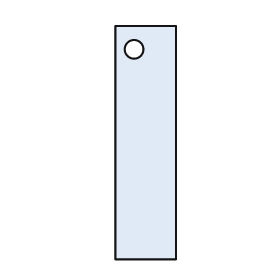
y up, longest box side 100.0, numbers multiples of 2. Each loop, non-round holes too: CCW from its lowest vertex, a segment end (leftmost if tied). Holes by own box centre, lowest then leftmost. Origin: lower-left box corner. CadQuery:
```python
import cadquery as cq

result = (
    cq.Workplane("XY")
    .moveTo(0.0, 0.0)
    .lineTo(26.0, 0.0)
    .lineTo(26.0, 100.0)
    .lineTo(0.0, 100.0)
    .close()
    .moveTo(8.0, 90.0)
    .circle(4.0)
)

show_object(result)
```